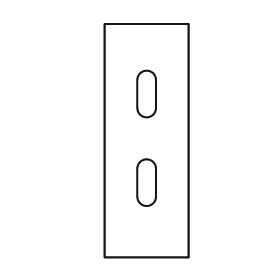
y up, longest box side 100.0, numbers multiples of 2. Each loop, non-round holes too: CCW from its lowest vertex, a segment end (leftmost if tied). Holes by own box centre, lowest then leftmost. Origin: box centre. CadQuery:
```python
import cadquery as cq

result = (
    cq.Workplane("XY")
    .moveTo(-18.0, -50.0)
    .lineTo(18.0, -50.0)
    .lineTo(18.0, 50.0)
    .lineTo(-18.0, 50.0)
    .close()
    .moveTo(-4.0, -24.0)
    .threePointArc((0.0, -28.0), (4.0, -24.0))
    .lineTo(4.0, -12.0)
    .threePointArc((0.0, -8.0), (-4.0, -12.0))
    .close()
    .moveTo(-4.0, 14.0)
    .threePointArc((0.0, 10.0), (4.0, 14.0))
    .lineTo(4.0, 26.0)
    .threePointArc((0.0, 30.0), (-4.0, 26.0))
    .close()
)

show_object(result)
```